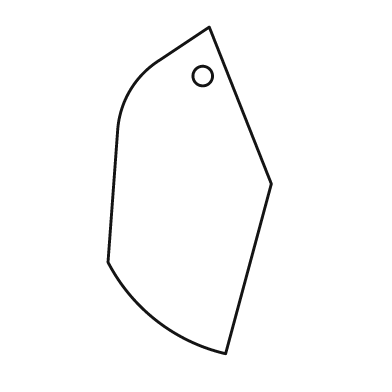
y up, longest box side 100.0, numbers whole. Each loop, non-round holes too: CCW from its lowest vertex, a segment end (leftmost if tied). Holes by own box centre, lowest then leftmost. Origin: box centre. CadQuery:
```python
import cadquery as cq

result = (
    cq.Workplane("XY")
    .moveTo(11.0, -50.0)
    .lineTo(25.0, 2.0)
    .lineTo(6.0, 50.0)
    .lineTo(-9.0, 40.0)
    .threePointArc((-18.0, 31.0), (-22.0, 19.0))
    .lineTo(-25.0, -22.0)
    .threePointArc((-10.0, -40.0), (11.0, -50.0))
    .close()
    .moveTo(4.0, 35.0)
    .circle(3.0)
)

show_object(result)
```